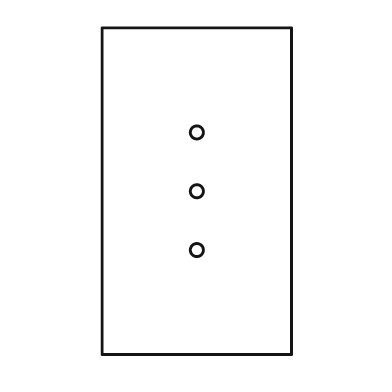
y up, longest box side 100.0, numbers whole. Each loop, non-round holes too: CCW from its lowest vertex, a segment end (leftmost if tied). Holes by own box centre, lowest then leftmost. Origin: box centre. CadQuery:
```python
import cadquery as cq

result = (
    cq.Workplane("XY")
    .moveTo(-29.0, -50.0)
    .lineTo(29.0, -50.0)
    .lineTo(29.0, 50.0)
    .lineTo(-29.0, 50.0)
    .close()
    .moveTo(0.0, -18.0)
    .circle(2.0)
    .moveTo(0.0, 0.0)
    .circle(2.0)
    .moveTo(0.0, 18.0)
    .circle(2.0)
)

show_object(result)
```